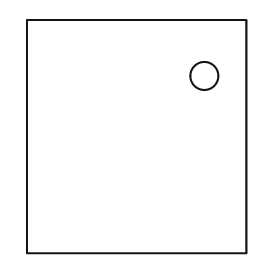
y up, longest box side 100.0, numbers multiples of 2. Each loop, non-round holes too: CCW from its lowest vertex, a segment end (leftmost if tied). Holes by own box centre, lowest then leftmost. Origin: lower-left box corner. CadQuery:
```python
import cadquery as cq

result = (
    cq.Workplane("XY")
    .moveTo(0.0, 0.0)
    .lineTo(94.0, 0.0)
    .lineTo(94.0, 100.0)
    .lineTo(0.0, 100.0)
    .close()
    .moveTo(76.0, 76.0)
    .circle(6.0)
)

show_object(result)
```